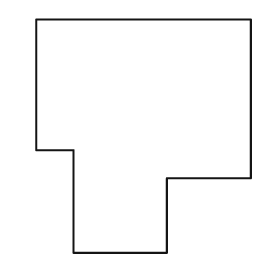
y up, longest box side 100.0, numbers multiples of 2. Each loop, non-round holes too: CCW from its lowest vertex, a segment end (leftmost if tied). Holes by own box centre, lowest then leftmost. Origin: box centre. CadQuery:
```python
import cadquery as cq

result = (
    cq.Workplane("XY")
    .moveTo(-30.0, -50.0)
    .lineTo(10.0, -50.0)
    .lineTo(10.0, -18.0)
    .lineTo(46.0, -18.0)
    .lineTo(46.0, 50.0)
    .lineTo(-46.0, 50.0)
    .lineTo(-46.0, -6.0)
    .lineTo(-30.0, -6.0)
    .close()
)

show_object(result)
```